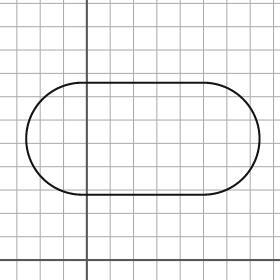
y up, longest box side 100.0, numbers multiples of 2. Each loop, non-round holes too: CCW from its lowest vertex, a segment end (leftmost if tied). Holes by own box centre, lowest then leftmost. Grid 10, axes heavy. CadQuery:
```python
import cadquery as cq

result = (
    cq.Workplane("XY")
    .moveTo(-2.0, 28.0)
    .lineTo(50.0, 28.0)
    .threePointArc((74.0, 52.0), (50.0, 76.0))
    .lineTo(-2.0, 76.0)
    .threePointArc((-26.0, 52.0), (-2.0, 28.0))
    .close()
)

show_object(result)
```